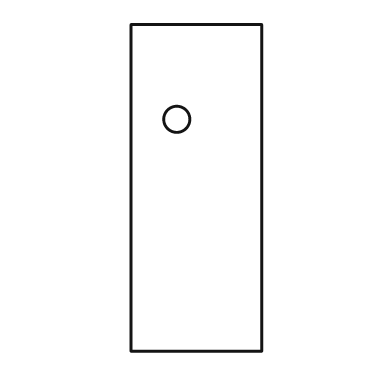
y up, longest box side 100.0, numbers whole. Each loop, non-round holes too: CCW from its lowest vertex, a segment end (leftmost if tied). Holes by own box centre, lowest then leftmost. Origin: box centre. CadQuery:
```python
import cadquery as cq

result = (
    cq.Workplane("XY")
    .moveTo(-20.0, -50.0)
    .lineTo(20.0, -50.0)
    .lineTo(20.0, 50.0)
    .lineTo(-20.0, 50.0)
    .close()
    .moveTo(-6.0, 21.0)
    .circle(4.0)
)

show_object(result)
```